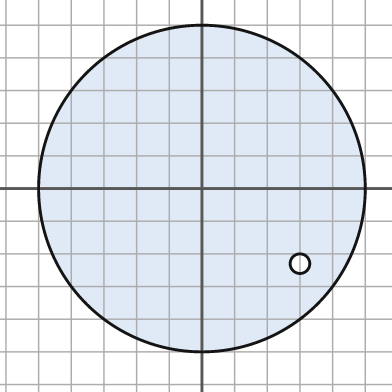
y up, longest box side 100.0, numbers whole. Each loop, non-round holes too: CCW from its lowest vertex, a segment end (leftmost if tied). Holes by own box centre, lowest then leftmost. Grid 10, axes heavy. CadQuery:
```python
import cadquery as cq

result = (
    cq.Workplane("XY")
    .moveTo(0.0, 0.0)
    .circle(50.0)
    .moveTo(30.0, -23.0)
    .circle(3.0)
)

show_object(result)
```